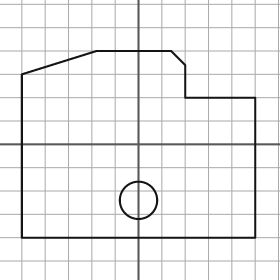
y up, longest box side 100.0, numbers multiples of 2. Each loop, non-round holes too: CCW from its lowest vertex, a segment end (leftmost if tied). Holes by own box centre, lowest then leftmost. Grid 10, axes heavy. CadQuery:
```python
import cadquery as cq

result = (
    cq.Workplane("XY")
    .moveTo(-50.0, -40.0)
    .lineTo(50.0, -40.0)
    .lineTo(50.0, 20.0)
    .lineTo(20.0, 20.0)
    .lineTo(20.0, 34.0)
    .lineTo(14.0, 40.0)
    .lineTo(-18.0, 40.0)
    .lineTo(-50.0, 30.0)
    .close()
    .moveTo(0.0, -24.0)
    .circle(8.0)
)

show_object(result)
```